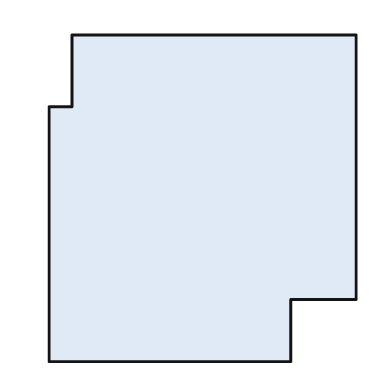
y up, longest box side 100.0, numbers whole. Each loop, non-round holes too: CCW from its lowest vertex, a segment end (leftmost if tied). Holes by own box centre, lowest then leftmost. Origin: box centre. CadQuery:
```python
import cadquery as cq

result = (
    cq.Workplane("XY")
    .moveTo(-47.0, -50.0)
    .lineTo(27.0, -50.0)
    .lineTo(27.0, -31.0)
    .lineTo(47.0, -31.0)
    .lineTo(47.0, 50.0)
    .lineTo(-40.0, 50.0)
    .lineTo(-40.0, 28.0)
    .lineTo(-47.0, 28.0)
    .close()
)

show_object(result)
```